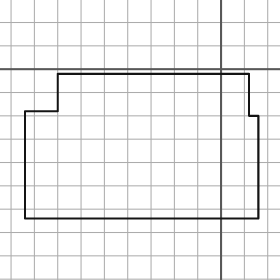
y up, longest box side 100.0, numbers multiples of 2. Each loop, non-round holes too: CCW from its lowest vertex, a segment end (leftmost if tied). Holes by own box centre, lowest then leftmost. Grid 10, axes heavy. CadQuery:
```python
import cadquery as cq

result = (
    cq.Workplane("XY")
    .moveTo(-84.0, -64.0)
    .lineTo(16.0, -64.0)
    .lineTo(16.0, -20.0)
    .lineTo(12.0, -20.0)
    .lineTo(12.0, -2.0)
    .lineTo(-70.0, -2.0)
    .lineTo(-70.0, -18.0)
    .lineTo(-84.0, -18.0)
    .close()
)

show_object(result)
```